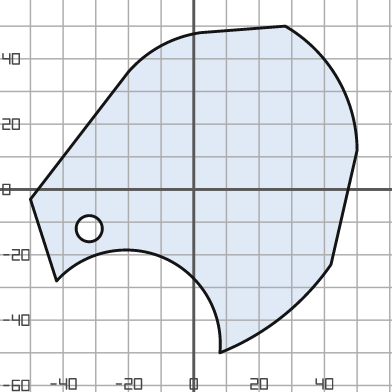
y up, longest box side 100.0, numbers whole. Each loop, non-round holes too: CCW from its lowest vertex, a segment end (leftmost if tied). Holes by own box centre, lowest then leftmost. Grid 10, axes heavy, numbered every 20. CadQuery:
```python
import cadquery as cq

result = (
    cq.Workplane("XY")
    .moveTo(8.0, -50.0)
    .threePointArc((27.0, -39.0), (42.0, -23.0))
    .lineTo(50.0, 12.0)
    .threePointArc((44.0, 34.0), (28.0, 50.0))
    .lineTo(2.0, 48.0)
    .threePointArc((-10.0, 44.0), (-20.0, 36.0))
    .lineTo(-50.0, -3.0)
    .lineTo(-42.0, -28.0)
    .threePointArc((-9.0, -21.0), (8.0, -50.0))
    .close()
    .moveTo(-32.0, -12.0)
    .circle(4.0)
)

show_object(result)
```